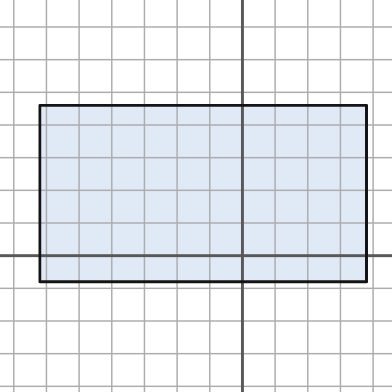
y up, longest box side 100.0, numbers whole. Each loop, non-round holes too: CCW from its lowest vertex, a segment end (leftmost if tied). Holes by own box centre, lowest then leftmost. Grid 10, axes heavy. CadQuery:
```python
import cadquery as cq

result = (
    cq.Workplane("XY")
    .moveTo(-62.0, -8.0)
    .lineTo(38.0, -8.0)
    .lineTo(38.0, 46.0)
    .lineTo(-62.0, 46.0)
    .close()
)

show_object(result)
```